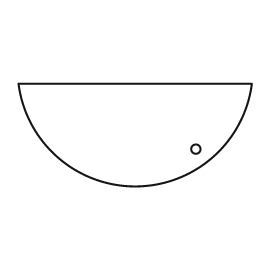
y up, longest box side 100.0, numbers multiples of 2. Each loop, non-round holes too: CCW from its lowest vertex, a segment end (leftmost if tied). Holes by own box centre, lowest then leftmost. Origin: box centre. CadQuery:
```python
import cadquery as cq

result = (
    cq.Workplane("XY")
    .moveTo(-50.0, 22.0)
    .threePointArc((0.0, -22.0), (50.0, 22.0))
    .close()
    .moveTo(26.0, -6.0)
    .circle(2.0)
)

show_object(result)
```